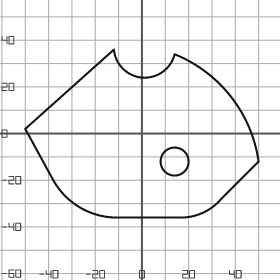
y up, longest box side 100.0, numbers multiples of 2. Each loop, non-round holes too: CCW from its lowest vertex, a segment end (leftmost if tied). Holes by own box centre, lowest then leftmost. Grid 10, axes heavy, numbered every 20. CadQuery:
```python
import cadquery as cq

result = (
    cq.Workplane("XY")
    .moveTo(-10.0, -36.0)
    .lineTo(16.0, -36.0)
    .threePointArc((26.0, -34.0), (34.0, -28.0))
    .lineTo(50.0, -12.0)
    .threePointArc((38.0, 16.0), (14.0, 34.0))
    .threePointArc((0.0, 24.0), (-12.0, 36.0))
    .lineTo(-50.0, 2.0)
    .lineTo(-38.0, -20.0)
    .threePointArc((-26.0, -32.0), (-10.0, -36.0))
    .close()
    .moveTo(14.0, -12.0)
    .circle(6.0)
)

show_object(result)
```